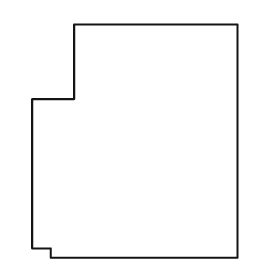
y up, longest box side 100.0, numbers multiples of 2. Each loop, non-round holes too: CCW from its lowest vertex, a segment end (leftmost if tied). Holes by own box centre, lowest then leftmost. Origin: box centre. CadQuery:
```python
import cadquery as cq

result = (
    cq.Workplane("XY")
    .moveTo(-36.0, -50.0)
    .lineTo(44.0, -50.0)
    .lineTo(44.0, 50.0)
    .lineTo(-26.0, 50.0)
    .lineTo(-26.0, 18.0)
    .lineTo(-44.0, 18.0)
    .lineTo(-44.0, -46.0)
    .lineTo(-36.0, -46.0)
    .close()
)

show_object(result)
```